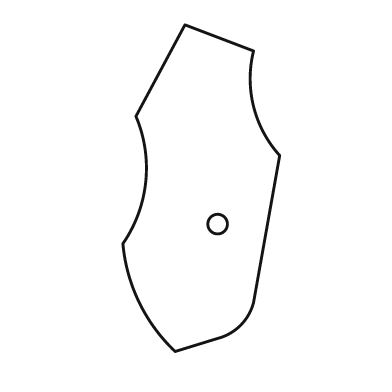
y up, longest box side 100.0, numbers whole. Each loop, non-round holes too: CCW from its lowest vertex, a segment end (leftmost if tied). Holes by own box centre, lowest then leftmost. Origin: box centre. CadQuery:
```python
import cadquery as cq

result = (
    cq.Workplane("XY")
    .moveTo(-8.0, -50.0)
    .lineTo(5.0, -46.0)
    .threePointArc((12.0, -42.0), (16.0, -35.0))
    .lineTo(24.0, 10.0)
    .threePointArc((16.0, 25.0), (16.0, 42.0))
    .lineTo(-5.0, 50.0)
    .lineTo(-20.0, 22.0)
    .threePointArc((-17.0, 2.0), (-24.0, -17.0))
    .threePointArc((-19.0, -35.0), (-8.0, -50.0))
    .close()
    .moveTo(5.0, -11.0)
    .circle(3.0)
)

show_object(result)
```